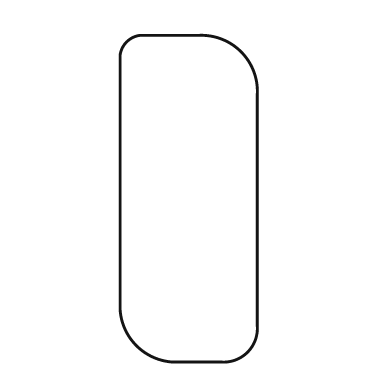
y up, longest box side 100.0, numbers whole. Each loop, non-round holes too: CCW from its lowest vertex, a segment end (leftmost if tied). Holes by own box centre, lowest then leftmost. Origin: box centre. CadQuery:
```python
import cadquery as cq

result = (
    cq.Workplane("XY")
    .moveTo(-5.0, -50.0)
    .lineTo(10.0, -50.0)
    .threePointArc((18.0, -47.0), (21.0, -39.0))
    .lineTo(21.0, 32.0)
    .threePointArc((16.0, 45.0), (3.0, 50.0))
    .lineTo(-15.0, 50.0)
    .threePointArc((-19.0, 48.0), (-21.0, 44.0))
    .lineTo(-21.0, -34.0)
    .threePointArc((-16.0, -45.0), (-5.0, -50.0))
    .close()
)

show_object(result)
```